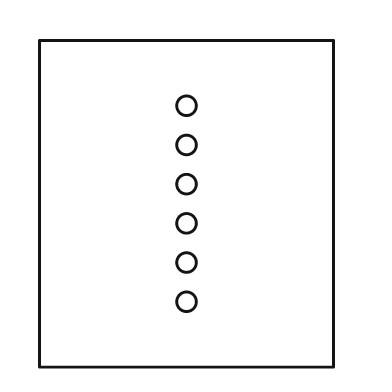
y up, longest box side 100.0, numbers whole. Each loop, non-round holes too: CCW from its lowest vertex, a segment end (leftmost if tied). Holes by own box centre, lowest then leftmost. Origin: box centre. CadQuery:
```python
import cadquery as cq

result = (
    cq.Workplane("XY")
    .moveTo(-45.0, -50.0)
    .lineTo(45.0, -50.0)
    .lineTo(45.0, 50.0)
    .lineTo(-45.0, 50.0)
    .close()
    .moveTo(0.0, -30.0)
    .circle(3.0)
    .moveTo(0.0, -18.0)
    .circle(3.0)
    .moveTo(0.0, -6.0)
    .circle(3.0)
    .moveTo(0.0, 6.0)
    .circle(3.0)
    .moveTo(0.0, 18.0)
    .circle(3.0)
    .moveTo(0.0, 30.0)
    .circle(3.0)
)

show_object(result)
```